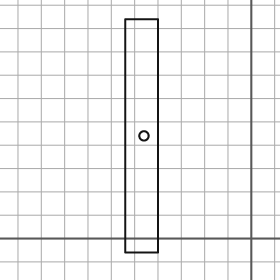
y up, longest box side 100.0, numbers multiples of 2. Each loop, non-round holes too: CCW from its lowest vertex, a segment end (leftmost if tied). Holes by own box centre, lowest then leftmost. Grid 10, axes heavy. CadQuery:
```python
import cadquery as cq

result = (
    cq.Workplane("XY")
    .moveTo(-54.0, -6.0)
    .lineTo(-40.0, -6.0)
    .lineTo(-40.0, 94.0)
    .lineTo(-54.0, 94.0)
    .close()
    .moveTo(-46.0, 44.0)
    .circle(2.0)
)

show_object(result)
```